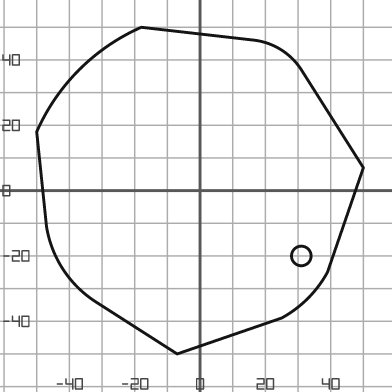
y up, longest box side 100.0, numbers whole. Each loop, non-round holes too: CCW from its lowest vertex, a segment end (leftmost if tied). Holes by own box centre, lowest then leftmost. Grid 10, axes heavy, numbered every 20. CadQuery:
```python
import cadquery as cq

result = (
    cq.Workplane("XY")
    .moveTo(-7.0, -50.0)
    .lineTo(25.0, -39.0)
    .threePointArc((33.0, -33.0), (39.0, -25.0))
    .lineTo(50.0, 7.0)
    .lineTo(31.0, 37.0)
    .threePointArc((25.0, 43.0), (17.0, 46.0))
    .lineTo(-18.0, 50.0)
    .threePointArc((-37.0, 37.0), (-50.0, 18.0))
    .lineTo(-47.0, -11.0)
    .threePointArc((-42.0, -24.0), (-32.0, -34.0))
    .close()
    .moveTo(31.0, -20.0)
    .circle(3.0)
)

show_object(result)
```